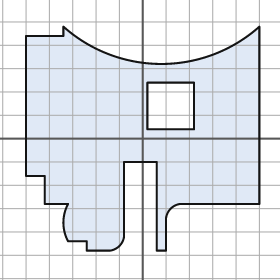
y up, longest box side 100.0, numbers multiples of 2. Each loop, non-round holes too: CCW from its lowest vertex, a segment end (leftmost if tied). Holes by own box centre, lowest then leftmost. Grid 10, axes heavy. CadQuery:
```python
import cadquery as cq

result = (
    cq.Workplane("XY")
    .moveTo(-24.0, -48.0)
    .lineTo(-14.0, -48.0)
    .threePointArc((-10.0, -46.0), (-8.0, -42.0))
    .lineTo(-8.0, -10.0)
    .lineTo(6.0, -10.0)
    .lineTo(6.0, -48.0)
    .lineTo(10.0, -48.0)
    .lineTo(10.0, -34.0)
    .threePointArc((12.0, -30.0), (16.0, -28.0))
    .lineTo(50.0, -28.0)
    .lineTo(50.0, 48.0)
    .threePointArc((8.0, 32.0), (-34.0, 48.0))
    .lineTo(-34.0, 44.0)
    .lineTo(-50.0, 44.0)
    .lineTo(-50.0, -16.0)
    .lineTo(-42.0, -16.0)
    .lineTo(-42.0, -28.0)
    .lineTo(-32.0, -28.0)
    .threePointArc((-34.0, -36.0), (-32.0, -44.0))
    .lineTo(-24.0, -44.0)
    .close()
    .moveTo(2.0, 4.0)
    .lineTo(22.0, 4.0)
    .lineTo(22.0, 24.0)
    .lineTo(2.0, 24.0)
    .close()
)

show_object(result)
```